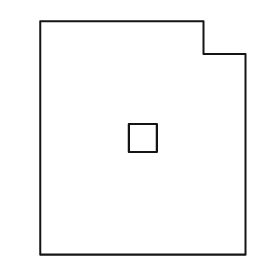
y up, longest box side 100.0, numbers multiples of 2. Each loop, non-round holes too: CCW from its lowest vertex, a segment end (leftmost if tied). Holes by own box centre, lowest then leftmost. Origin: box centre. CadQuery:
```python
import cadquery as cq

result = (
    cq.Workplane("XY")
    .moveTo(-44.0, -50.0)
    .lineTo(44.0, -50.0)
    .lineTo(44.0, 36.0)
    .lineTo(26.0, 36.0)
    .lineTo(26.0, 50.0)
    .lineTo(-44.0, 50.0)
    .close()
    .moveTo(-6.0, -6.0)
    .lineTo(6.0, -6.0)
    .lineTo(6.0, 6.0)
    .lineTo(-6.0, 6.0)
    .close()
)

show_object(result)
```